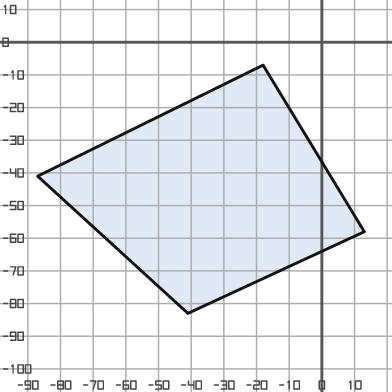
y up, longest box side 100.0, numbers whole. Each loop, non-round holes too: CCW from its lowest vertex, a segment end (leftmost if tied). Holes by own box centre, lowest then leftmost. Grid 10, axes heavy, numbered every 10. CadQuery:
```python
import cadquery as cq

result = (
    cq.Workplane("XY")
    .moveTo(-41.0, -83.0)
    .lineTo(13.0, -58.0)
    .lineTo(-18.0, -7.0)
    .lineTo(-87.0, -41.0)
    .close()
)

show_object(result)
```